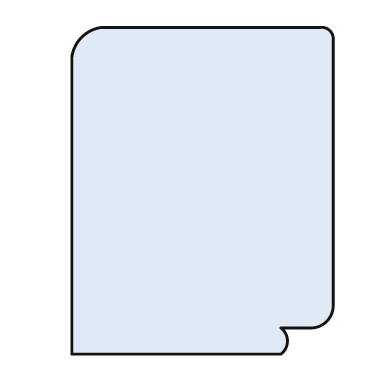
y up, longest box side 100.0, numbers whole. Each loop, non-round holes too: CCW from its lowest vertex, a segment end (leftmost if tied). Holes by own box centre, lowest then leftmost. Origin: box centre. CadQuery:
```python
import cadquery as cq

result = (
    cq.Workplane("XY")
    .moveTo(-40.0, -50.0)
    .lineTo(24.0, -50.0)
    .threePointArc((26.0, -46.0), (24.0, -42.0))
    .lineTo(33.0, -42.0)
    .threePointArc((38.0, -40.0), (40.0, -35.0))
    .lineTo(40.0, 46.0)
    .threePointArc((39.0, 49.0), (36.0, 50.0))
    .lineTo(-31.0, 50.0)
    .threePointArc((-37.0, 47.0), (-40.0, 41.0))
    .close()
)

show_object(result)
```